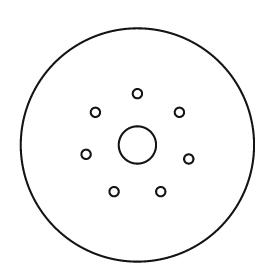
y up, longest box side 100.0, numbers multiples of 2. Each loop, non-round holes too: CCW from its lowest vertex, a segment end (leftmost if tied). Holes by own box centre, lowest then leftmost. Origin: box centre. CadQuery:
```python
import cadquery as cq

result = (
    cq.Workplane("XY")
    .moveTo(0.0, 0.0)
    .circle(50.0)
    .moveTo(-10.0, -20.0)
    .circle(2.0)
    .moveTo(10.0, -20.0)
    .circle(2.0)
    .moveTo(22.0, -6.0)
    .circle(2.0)
    .moveTo(-22.0, -4.0)
    .circle(2.0)
    .moveTo(0.0, 0.0)
    .circle(8.0)
    .moveTo(-18.0, 14.0)
    .circle(2.0)
    .moveTo(18.0, 14.0)
    .circle(2.0)
    .moveTo(0.0, 22.0)
    .circle(2.0)
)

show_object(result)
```